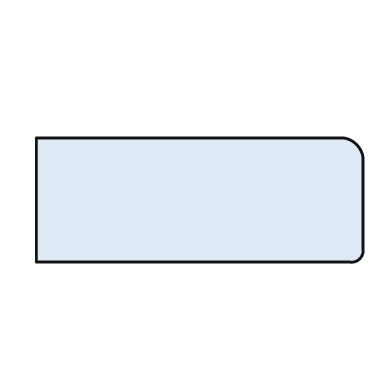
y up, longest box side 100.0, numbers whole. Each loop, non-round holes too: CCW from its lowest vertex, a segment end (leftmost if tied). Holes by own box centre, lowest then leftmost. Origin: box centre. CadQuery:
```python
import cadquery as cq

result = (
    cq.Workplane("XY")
    .moveTo(-50.0, -19.0)
    .lineTo(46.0, -19.0)
    .threePointArc((49.0, -18.0), (50.0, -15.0))
    .lineTo(50.0, 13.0)
    .threePointArc((48.0, 17.0), (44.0, 19.0))
    .lineTo(-50.0, 19.0)
    .close()
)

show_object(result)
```